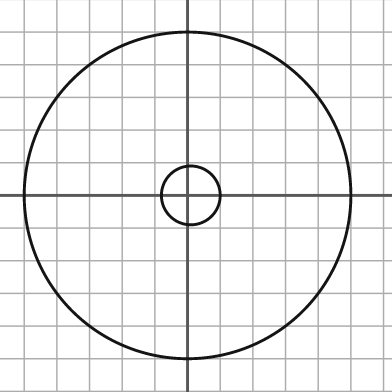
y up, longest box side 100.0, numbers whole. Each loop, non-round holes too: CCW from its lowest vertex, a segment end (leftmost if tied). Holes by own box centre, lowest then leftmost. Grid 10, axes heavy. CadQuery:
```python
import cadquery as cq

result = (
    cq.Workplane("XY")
    .moveTo(0.0, 0.0)
    .circle(50.0)
    .moveTo(1.0, 0.0)
    .circle(9.0)
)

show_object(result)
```